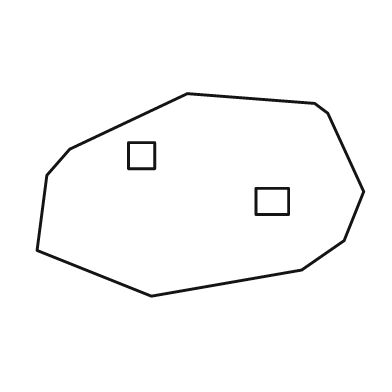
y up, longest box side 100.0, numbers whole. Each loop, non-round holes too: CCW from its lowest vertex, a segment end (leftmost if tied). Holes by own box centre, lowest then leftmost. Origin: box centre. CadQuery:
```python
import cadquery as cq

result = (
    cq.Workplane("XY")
    .moveTo(-15.0, -31.0)
    .lineTo(31.0, -23.0)
    .lineTo(44.0, -14.0)
    .lineTo(50.0, 1.0)
    .lineTo(39.0, 25.0)
    .lineTo(35.0, 28.0)
    .lineTo(-4.0, 31.0)
    .lineTo(-40.0, 14.0)
    .lineTo(-47.0, 6.0)
    .lineTo(-50.0, -17.0)
    .close()
    .moveTo(17.0, -6.0)
    .lineTo(27.0, -6.0)
    .lineTo(27.0, 2.0)
    .lineTo(17.0, 2.0)
    .close()
    .moveTo(-22.0, 8.0)
    .lineTo(-14.0, 8.0)
    .lineTo(-14.0, 16.0)
    .lineTo(-22.0, 16.0)
    .close()
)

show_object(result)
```